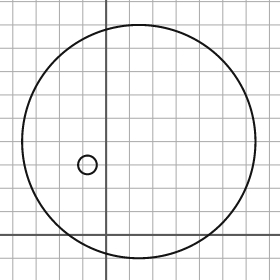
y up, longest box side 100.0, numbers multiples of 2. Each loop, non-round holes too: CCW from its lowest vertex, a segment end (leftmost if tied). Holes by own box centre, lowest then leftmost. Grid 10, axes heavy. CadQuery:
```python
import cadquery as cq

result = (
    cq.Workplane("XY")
    .moveTo(14.0, 40.0)
    .circle(50.0)
    .moveTo(-8.0, 30.0)
    .circle(4.0)
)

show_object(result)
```